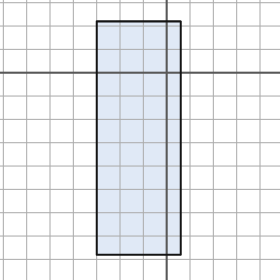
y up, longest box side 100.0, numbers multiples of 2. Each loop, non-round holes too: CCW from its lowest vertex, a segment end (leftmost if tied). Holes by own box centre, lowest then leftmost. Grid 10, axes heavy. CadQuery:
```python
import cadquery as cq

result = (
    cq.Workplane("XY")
    .moveTo(-30.0, -78.0)
    .lineTo(6.0, -78.0)
    .lineTo(6.0, 22.0)
    .lineTo(-30.0, 22.0)
    .close()
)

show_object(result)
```